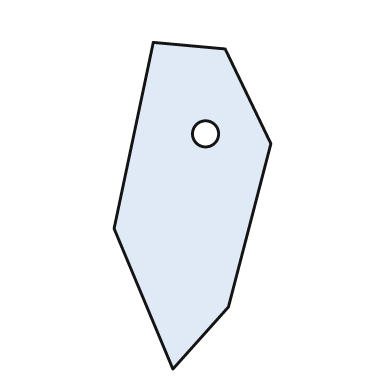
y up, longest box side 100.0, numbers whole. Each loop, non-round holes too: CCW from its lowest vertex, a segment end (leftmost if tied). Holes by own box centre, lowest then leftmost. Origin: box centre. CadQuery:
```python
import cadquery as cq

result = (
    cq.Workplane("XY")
    .moveTo(-6.0, -50.0)
    .lineTo(11.0, -31.0)
    .lineTo(24.0, 19.0)
    .lineTo(10.0, 48.0)
    .lineTo(-12.0, 50.0)
    .lineTo(-24.0, -7.0)
    .close()
    .moveTo(4.0, 22.0)
    .circle(4.0)
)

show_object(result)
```